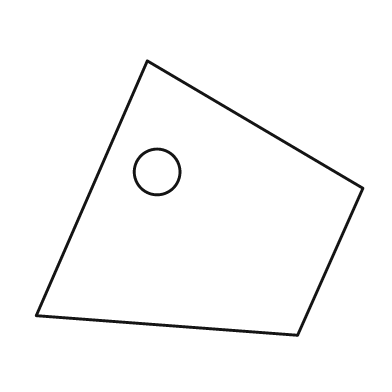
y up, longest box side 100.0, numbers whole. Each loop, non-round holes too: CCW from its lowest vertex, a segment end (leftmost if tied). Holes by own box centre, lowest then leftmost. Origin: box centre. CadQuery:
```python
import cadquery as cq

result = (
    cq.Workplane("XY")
    .moveTo(30.0, -42.0)
    .lineTo(50.0, 3.0)
    .lineTo(-16.0, 42.0)
    .lineTo(-50.0, -36.0)
    .close()
    .moveTo(-13.0, 8.0)
    .circle(7.0)
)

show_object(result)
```